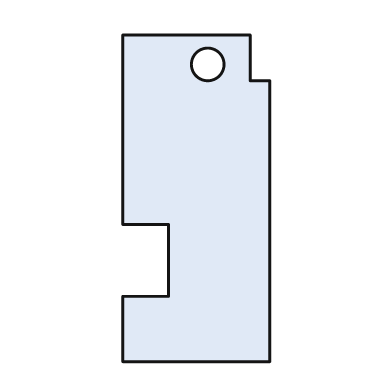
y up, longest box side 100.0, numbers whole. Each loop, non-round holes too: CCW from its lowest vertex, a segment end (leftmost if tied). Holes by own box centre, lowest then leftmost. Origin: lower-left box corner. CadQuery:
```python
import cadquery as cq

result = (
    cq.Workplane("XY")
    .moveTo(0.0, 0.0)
    .lineTo(45.0, 0.0)
    .lineTo(45.0, 86.0)
    .lineTo(39.0, 86.0)
    .lineTo(39.0, 100.0)
    .lineTo(0.0, 100.0)
    .lineTo(0.0, 42.0)
    .lineTo(14.0, 42.0)
    .lineTo(14.0, 20.0)
    .lineTo(0.0, 20.0)
    .close()
    .moveTo(26.0, 91.0)
    .circle(5.0)
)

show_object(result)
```